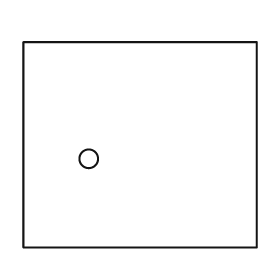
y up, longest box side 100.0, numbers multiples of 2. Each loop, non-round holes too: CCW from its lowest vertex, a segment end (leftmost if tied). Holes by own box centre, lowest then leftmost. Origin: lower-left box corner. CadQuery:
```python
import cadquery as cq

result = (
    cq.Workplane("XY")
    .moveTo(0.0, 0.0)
    .lineTo(100.0, 0.0)
    .lineTo(100.0, 88.0)
    .lineTo(0.0, 88.0)
    .close()
    .moveTo(28.0, 38.0)
    .circle(4.0)
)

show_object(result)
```